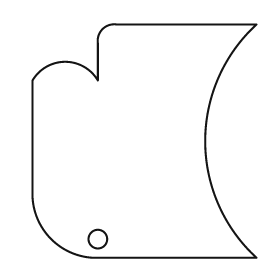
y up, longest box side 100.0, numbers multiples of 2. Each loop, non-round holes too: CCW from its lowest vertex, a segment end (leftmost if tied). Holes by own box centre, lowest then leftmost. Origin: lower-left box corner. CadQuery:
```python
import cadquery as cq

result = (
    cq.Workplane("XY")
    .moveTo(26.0, 0.0)
    .lineTo(96.0, 0.0)
    .threePointArc((74.0, 50.0), (96.0, 100.0))
    .lineTo(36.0, 100.0)
    .threePointArc((30.0, 98.0), (28.0, 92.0))
    .lineTo(28.0, 76.0)
    .threePointArc((14.0, 84.0), (0.0, 76.0))
    .lineTo(0.0, 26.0)
    .threePointArc((8.0, 8.0), (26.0, 0.0))
    .close()
    .moveTo(28.0, 8.0)
    .circle(4.0)
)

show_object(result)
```